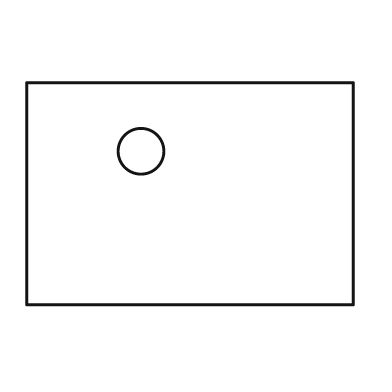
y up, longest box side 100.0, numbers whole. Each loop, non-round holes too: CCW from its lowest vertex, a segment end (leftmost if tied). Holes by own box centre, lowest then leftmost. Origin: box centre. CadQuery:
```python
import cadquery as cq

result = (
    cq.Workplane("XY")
    .moveTo(-50.0, -34.0)
    .lineTo(50.0, -34.0)
    .lineTo(50.0, 34.0)
    .lineTo(-50.0, 34.0)
    .close()
    .moveTo(-15.0, 13.0)
    .circle(7.0)
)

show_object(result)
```